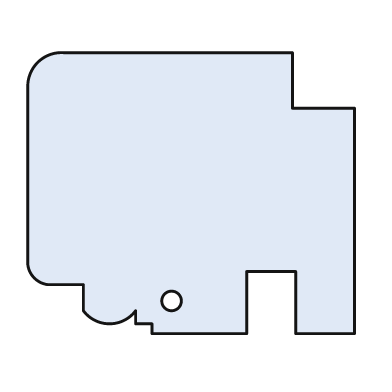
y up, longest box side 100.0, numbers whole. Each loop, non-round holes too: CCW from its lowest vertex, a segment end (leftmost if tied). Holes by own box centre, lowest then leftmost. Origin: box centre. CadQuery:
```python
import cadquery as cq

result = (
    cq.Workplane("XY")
    .moveTo(-12.0, -43.0)
    .lineTo(17.0, -43.0)
    .lineTo(17.0, -24.0)
    .lineTo(32.0, -24.0)
    .lineTo(32.0, -43.0)
    .lineTo(50.0, -43.0)
    .lineTo(50.0, 26.0)
    .lineTo(31.0, 26.0)
    .lineTo(31.0, 43.0)
    .lineTo(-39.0, 43.0)
    .threePointArc((-47.0, 40.0), (-50.0, 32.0))
    .lineTo(-50.0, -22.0)
    .threePointArc((-48.0, -26.0), (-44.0, -28.0))
    .lineTo(-33.0, -28.0)
    .lineTo(-33.0, -36.0)
    .threePointArc((-25.0, -40.0), (-17.0, -36.0))
    .lineTo(-17.0, -40.0)
    .lineTo(-12.0, -40.0)
    .close()
    .moveTo(-6.0, -33.0)
    .circle(3.0)
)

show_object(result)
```